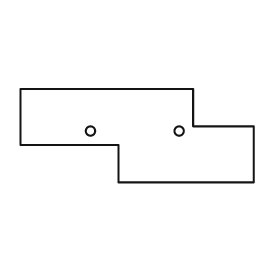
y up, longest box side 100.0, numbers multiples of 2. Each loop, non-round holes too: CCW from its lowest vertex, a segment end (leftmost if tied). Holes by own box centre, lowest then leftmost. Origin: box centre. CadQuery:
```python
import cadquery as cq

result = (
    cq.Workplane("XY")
    .moveTo(-8.0, -20.0)
    .lineTo(50.0, -20.0)
    .lineTo(50.0, 4.0)
    .lineTo(24.0, 4.0)
    .lineTo(24.0, 20.0)
    .lineTo(-50.0, 20.0)
    .lineTo(-50.0, -4.0)
    .lineTo(-8.0, -4.0)
    .close()
    .moveTo(-20.0, 2.0)
    .circle(2.0)
    .moveTo(18.0, 2.0)
    .circle(2.0)
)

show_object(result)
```